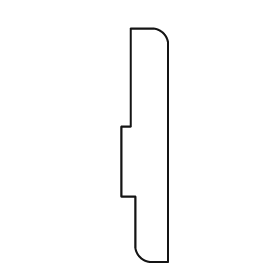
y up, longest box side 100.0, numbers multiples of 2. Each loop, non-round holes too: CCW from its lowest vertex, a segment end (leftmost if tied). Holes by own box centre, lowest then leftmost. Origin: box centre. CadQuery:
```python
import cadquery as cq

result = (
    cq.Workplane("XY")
    .moveTo(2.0, -50.0)
    .lineTo(10.0, -50.0)
    .lineTo(10.0, 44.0)
    .threePointArc((8.0, 48.0), (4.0, 50.0))
    .lineTo(-6.0, 50.0)
    .lineTo(-6.0, 8.0)
    .lineTo(-10.0, 8.0)
    .lineTo(-10.0, -22.0)
    .lineTo(-4.0, -22.0)
    .lineTo(-4.0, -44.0)
    .threePointArc((-2.0, -48.0), (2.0, -50.0))
    .close()
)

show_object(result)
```